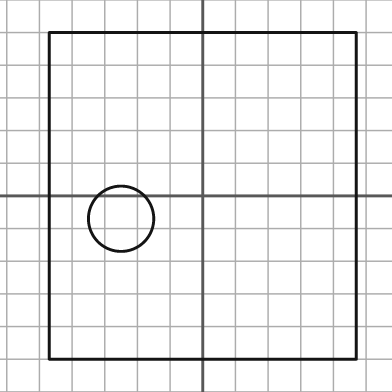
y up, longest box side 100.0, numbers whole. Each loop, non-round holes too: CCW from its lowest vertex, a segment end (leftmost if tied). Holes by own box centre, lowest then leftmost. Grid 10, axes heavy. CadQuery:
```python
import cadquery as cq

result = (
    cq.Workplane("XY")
    .moveTo(-47.0, -50.0)
    .lineTo(47.0, -50.0)
    .lineTo(47.0, 50.0)
    .lineTo(-47.0, 50.0)
    .close()
    .moveTo(-25.0, -7.0)
    .circle(10.0)
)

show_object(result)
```